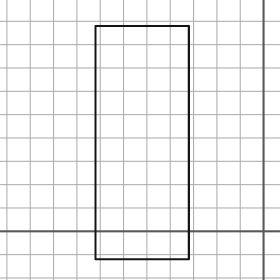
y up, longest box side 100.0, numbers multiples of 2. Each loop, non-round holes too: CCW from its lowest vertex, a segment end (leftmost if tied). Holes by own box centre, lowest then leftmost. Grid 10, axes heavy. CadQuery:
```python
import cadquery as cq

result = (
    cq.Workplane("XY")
    .moveTo(-72.0, -12.0)
    .lineTo(-32.0, -12.0)
    .lineTo(-32.0, 88.0)
    .lineTo(-72.0, 88.0)
    .close()
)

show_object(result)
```